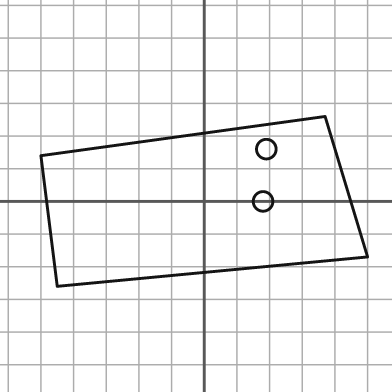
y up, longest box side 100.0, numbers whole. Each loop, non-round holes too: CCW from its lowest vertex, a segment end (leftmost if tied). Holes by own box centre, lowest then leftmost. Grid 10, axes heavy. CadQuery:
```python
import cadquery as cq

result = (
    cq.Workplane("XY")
    .moveTo(-45.0, -26.0)
    .lineTo(50.0, -17.0)
    .lineTo(37.0, 26.0)
    .lineTo(-50.0, 14.0)
    .close()
    .moveTo(18.0, 0.0)
    .circle(3.0)
    .moveTo(19.0, 16.0)
    .circle(3.0)
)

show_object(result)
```